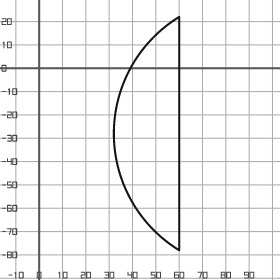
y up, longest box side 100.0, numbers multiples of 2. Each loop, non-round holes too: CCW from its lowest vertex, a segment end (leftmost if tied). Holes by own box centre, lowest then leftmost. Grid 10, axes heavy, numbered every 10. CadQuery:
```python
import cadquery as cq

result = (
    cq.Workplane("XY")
    .moveTo(60.0, -78.0)
    .lineTo(60.0, 22.0)
    .threePointArc((32.0, -28.0), (60.0, -78.0))
    .close()
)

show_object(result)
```